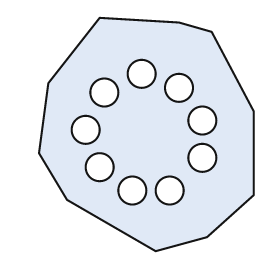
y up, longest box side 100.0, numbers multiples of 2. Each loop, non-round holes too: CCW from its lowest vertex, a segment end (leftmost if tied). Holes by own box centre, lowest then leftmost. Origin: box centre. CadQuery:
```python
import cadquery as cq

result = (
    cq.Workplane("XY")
    .moveTo(4.0, -50.0)
    .lineTo(26.0, -44.0)
    .lineTo(46.0, -26.0)
    .lineTo(46.0, 10.0)
    .lineTo(28.0, 44.0)
    .lineTo(14.0, 48.0)
    .lineTo(-20.0, 50.0)
    .lineTo(-42.0, 22.0)
    .lineTo(-46.0, -8.0)
    .lineTo(-34.0, -28.0)
    .close()
    .moveTo(-6.0, -24.0)
    .circle(6.0)
    .moveTo(10.0, -24.0)
    .circle(6.0)
    .moveTo(-20.0, -14.0)
    .circle(6.0)
    .moveTo(24.0, -10.0)
    .circle(6.0)
    .moveTo(-26.0, 2.0)
    .circle(6.0)
    .moveTo(24.0, 6.0)
    .circle(6.0)
    .moveTo(-18.0, 18.0)
    .circle(6.0)
    .moveTo(14.0, 20.0)
    .circle(6.0)
    .moveTo(-2.0, 26.0)
    .circle(6.0)
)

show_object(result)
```